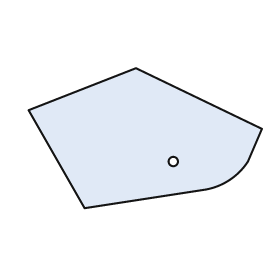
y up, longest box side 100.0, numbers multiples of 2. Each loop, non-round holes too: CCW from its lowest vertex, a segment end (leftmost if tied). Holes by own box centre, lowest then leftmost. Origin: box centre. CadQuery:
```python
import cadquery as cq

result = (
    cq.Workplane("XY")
    .moveTo(-26.0, -30.0)
    .lineTo(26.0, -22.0)
    .threePointArc((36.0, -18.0), (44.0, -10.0))
    .lineTo(50.0, 4.0)
    .lineTo(-4.0, 30.0)
    .lineTo(-50.0, 12.0)
    .close()
    .moveTo(12.0, -10.0)
    .circle(2.0)
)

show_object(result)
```